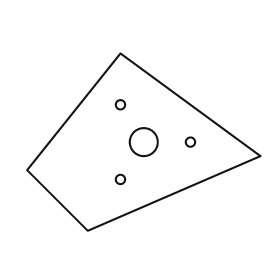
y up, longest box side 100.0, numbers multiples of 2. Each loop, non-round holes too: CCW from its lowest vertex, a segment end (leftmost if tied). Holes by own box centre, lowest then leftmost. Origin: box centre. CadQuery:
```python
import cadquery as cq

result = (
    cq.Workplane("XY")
    .moveTo(-24.0, -38.0)
    .lineTo(50.0, -6.0)
    .lineTo(-10.0, 38.0)
    .lineTo(-50.0, -12.0)
    .close()
    .moveTo(-10.0, -16.0)
    .circle(2.0)
    .moveTo(0.0, 0.0)
    .circle(6.0)
    .moveTo(20.0, 0.0)
    .circle(2.0)
    .moveTo(-10.0, 16.0)
    .circle(2.0)
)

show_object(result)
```